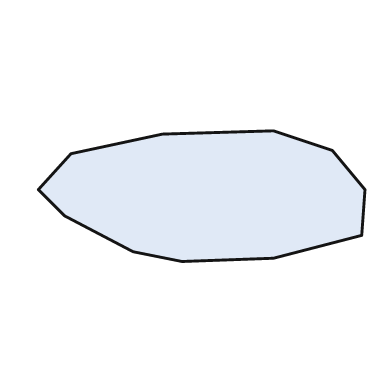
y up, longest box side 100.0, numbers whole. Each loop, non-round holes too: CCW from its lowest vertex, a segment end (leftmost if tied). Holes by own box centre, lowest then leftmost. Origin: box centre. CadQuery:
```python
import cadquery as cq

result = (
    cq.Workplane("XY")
    .moveTo(-6.0, -20.0)
    .lineTo(22.0, -19.0)
    .lineTo(49.0, -12.0)
    .lineTo(50.0, 2.0)
    .lineTo(40.0, 14.0)
    .lineTo(22.0, 20.0)
    .lineTo(-12.0, 19.0)
    .lineTo(-40.0, 13.0)
    .lineTo(-50.0, 2.0)
    .lineTo(-42.0, -6.0)
    .lineTo(-21.0, -17.0)
    .close()
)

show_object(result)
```